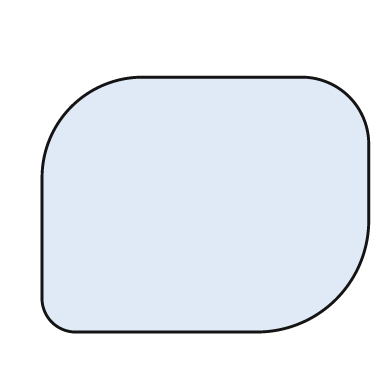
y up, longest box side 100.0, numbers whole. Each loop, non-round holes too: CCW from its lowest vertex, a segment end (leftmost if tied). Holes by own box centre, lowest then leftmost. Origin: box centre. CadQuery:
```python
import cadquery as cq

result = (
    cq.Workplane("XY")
    .moveTo(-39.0, -39.0)
    .lineTo(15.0, -39.0)
    .threePointArc((40.0, -29.0), (50.0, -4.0))
    .lineTo(50.0, 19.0)
    .threePointArc((44.0, 33.0), (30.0, 39.0))
    .lineTo(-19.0, 39.0)
    .threePointArc((-41.0, 30.0), (-50.0, 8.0))
    .lineTo(-50.0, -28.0)
    .threePointArc((-47.0, -36.0), (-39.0, -39.0))
    .close()
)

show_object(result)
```